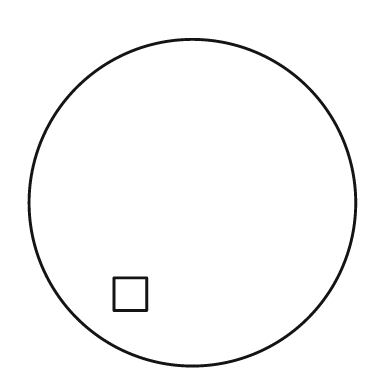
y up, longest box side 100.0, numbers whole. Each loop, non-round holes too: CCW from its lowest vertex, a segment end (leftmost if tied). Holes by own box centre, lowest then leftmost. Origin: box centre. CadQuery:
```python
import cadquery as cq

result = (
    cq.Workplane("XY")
    .moveTo(0.0, 0.0)
    .circle(50.0)
    .moveTo(-24.0, -33.0)
    .lineTo(-14.0, -33.0)
    .lineTo(-14.0, -23.0)
    .lineTo(-24.0, -23.0)
    .close()
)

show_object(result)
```